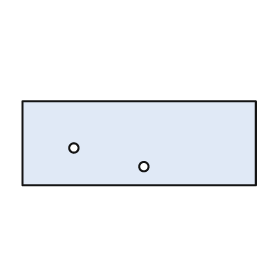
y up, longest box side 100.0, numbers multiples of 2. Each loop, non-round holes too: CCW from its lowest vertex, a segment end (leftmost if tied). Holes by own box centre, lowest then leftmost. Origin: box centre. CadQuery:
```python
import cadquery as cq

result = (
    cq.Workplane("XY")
    .moveTo(-50.0, -18.0)
    .lineTo(50.0, -18.0)
    .lineTo(50.0, 18.0)
    .lineTo(-50.0, 18.0)
    .close()
    .moveTo(2.0, -10.0)
    .circle(2.0)
    .moveTo(-28.0, -2.0)
    .circle(2.0)
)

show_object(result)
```